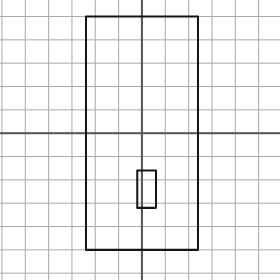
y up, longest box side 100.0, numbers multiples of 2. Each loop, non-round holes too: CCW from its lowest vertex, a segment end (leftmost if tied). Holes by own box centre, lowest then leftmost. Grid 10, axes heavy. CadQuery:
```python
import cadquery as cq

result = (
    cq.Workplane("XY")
    .moveTo(-24.0, -50.0)
    .lineTo(24.0, -50.0)
    .lineTo(24.0, 50.0)
    .lineTo(-24.0, 50.0)
    .close()
    .moveTo(-2.0, -32.0)
    .lineTo(6.0, -32.0)
    .lineTo(6.0, -16.0)
    .lineTo(-2.0, -16.0)
    .close()
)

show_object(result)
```